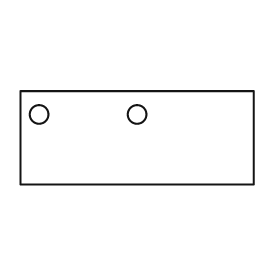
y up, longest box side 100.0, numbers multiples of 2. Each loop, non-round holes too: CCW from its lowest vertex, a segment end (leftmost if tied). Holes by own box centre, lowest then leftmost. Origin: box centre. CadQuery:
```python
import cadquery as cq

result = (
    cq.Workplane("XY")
    .moveTo(-50.0, -20.0)
    .lineTo(50.0, -20.0)
    .lineTo(50.0, 20.0)
    .lineTo(-50.0, 20.0)
    .close()
    .moveTo(-42.0, 10.0)
    .circle(4.0)
    .moveTo(0.0, 10.0)
    .circle(4.0)
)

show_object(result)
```